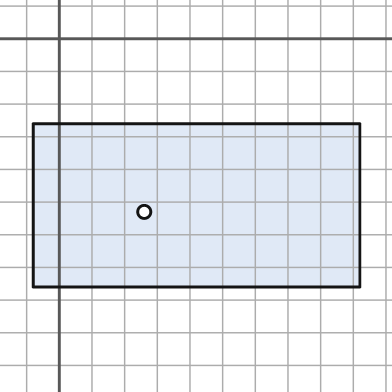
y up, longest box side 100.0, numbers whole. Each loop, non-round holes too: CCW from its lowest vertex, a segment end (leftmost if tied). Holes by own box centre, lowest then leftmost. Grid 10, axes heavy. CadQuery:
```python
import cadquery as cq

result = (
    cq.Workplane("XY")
    .moveTo(-8.0, -76.0)
    .lineTo(92.0, -76.0)
    .lineTo(92.0, -26.0)
    .lineTo(-8.0, -26.0)
    .close()
    .moveTo(26.0, -53.0)
    .circle(2.0)
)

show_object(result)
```